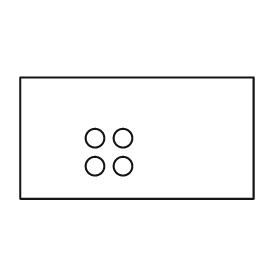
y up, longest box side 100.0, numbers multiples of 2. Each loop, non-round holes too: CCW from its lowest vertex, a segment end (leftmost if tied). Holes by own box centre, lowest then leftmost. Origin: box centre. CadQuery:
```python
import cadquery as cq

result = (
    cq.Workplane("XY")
    .moveTo(-50.0, -26.0)
    .lineTo(50.0, -26.0)
    .lineTo(50.0, 26.0)
    .lineTo(-50.0, 26.0)
    .close()
    .moveTo(-18.0, -12.0)
    .circle(4.0)
    .moveTo(-6.0, -12.0)
    .circle(4.0)
    .moveTo(-18.0, 0.0)
    .circle(4.0)
    .moveTo(-6.0, 0.0)
    .circle(4.0)
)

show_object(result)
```